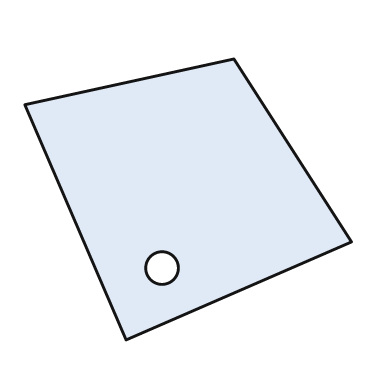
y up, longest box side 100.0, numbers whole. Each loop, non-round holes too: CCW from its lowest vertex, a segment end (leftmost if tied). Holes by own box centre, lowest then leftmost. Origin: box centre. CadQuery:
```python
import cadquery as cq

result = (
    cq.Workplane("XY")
    .moveTo(-19.0, -43.0)
    .lineTo(50.0, -13.0)
    .lineTo(14.0, 43.0)
    .lineTo(-50.0, 29.0)
    .close()
    .moveTo(-8.0, -21.0)
    .circle(5.0)
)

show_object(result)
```